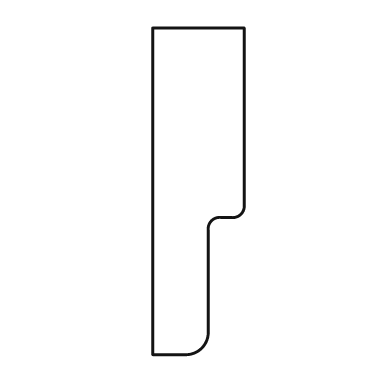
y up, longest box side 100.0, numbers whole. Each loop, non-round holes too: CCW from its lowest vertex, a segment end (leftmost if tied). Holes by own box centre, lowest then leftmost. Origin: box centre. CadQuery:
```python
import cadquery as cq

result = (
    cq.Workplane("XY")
    .moveTo(-14.0, -50.0)
    .lineTo(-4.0, -50.0)
    .threePointArc((1.0, -48.0), (3.0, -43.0))
    .lineTo(3.0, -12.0)
    .threePointArc((4.0, -9.0), (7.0, -8.0))
    .lineTo(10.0, -8.0)
    .threePointArc((13.0, -7.0), (14.0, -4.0))
    .lineTo(14.0, 50.0)
    .lineTo(-14.0, 50.0)
    .close()
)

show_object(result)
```